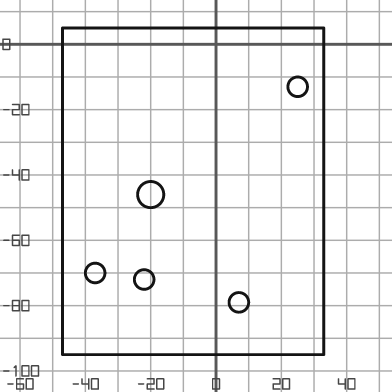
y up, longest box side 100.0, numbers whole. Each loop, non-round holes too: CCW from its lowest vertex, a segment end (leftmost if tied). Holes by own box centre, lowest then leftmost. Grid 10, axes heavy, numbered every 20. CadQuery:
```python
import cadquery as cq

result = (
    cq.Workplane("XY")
    .moveTo(-47.0, -95.0)
    .lineTo(33.0, -95.0)
    .lineTo(33.0, 5.0)
    .lineTo(-47.0, 5.0)
    .close()
    .moveTo(7.0, -79.0)
    .circle(3.0)
    .moveTo(-22.0, -72.0)
    .circle(3.0)
    .moveTo(-37.0, -70.0)
    .circle(3.0)
    .moveTo(-20.0, -46.0)
    .circle(4.0)
    .moveTo(25.0, -13.0)
    .circle(3.0)
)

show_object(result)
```